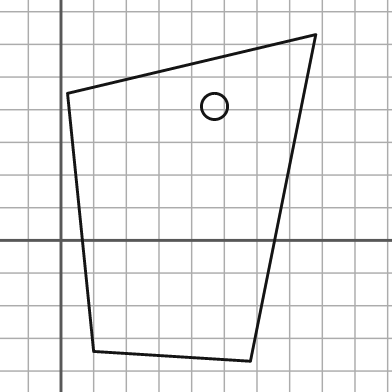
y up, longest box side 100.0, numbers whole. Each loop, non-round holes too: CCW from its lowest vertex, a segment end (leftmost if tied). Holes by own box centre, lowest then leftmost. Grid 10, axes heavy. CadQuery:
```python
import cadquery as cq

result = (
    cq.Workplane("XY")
    .moveTo(58.0, -37.0)
    .lineTo(78.0, 63.0)
    .lineTo(2.0, 45.0)
    .lineTo(10.0, -34.0)
    .close()
    .moveTo(47.0, 41.0)
    .circle(4.0)
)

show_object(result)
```